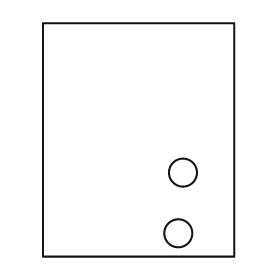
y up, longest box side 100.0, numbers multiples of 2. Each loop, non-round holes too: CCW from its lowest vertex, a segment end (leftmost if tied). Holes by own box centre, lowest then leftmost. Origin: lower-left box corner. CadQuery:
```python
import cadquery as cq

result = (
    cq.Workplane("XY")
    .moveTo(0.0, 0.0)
    .lineTo(82.0, 0.0)
    .lineTo(82.0, 100.0)
    .lineTo(0.0, 100.0)
    .close()
    .moveTo(58.0, 10.0)
    .circle(6.0)
    .moveTo(60.0, 36.0)
    .circle(6.0)
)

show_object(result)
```